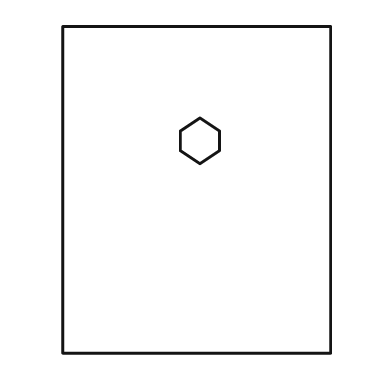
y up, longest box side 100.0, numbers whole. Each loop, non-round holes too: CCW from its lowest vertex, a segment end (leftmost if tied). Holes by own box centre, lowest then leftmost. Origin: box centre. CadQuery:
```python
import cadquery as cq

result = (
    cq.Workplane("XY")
    .moveTo(-41.0, -50.0)
    .lineTo(41.0, -50.0)
    .lineTo(41.0, 50.0)
    .lineTo(-41.0, 50.0)
    .close()
    .moveTo(1.0, 8.0)
    .lineTo(7.0, 12.0)
    .lineTo(7.0, 18.0)
    .lineTo(1.0, 22.0)
    .lineTo(-5.0, 18.0)
    .lineTo(-5.0, 12.0)
    .close()
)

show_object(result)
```